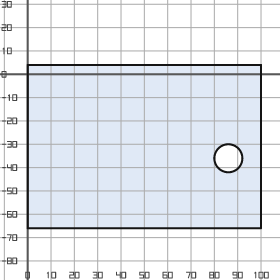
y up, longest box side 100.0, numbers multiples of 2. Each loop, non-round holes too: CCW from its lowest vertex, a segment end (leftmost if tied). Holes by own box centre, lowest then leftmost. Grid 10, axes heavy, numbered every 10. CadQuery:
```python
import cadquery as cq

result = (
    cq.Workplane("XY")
    .moveTo(0.0, -66.0)
    .lineTo(100.0, -66.0)
    .lineTo(100.0, 4.0)
    .lineTo(0.0, 4.0)
    .close()
    .moveTo(86.0, -36.0)
    .circle(6.0)
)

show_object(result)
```